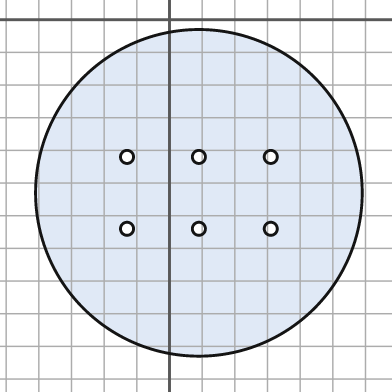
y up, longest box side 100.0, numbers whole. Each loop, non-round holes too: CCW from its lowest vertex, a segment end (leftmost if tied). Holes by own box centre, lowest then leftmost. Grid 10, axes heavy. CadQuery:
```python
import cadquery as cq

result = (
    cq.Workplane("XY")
    .moveTo(9.0, -53.0)
    .circle(50.0)
    .moveTo(-13.0, -64.0)
    .circle(2.0)
    .moveTo(9.0, -64.0)
    .circle(2.0)
    .moveTo(31.0, -64.0)
    .circle(2.0)
    .moveTo(-13.0, -42.0)
    .circle(2.0)
    .moveTo(9.0, -42.0)
    .circle(2.0)
    .moveTo(31.0, -42.0)
    .circle(2.0)
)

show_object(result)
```